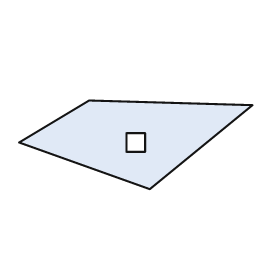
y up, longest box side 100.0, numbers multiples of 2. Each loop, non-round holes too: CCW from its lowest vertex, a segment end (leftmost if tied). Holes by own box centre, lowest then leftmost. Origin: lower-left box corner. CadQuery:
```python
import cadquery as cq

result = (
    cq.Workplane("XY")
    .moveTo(56.0, 0.0)
    .lineTo(100.0, 36.0)
    .lineTo(30.0, 38.0)
    .lineTo(0.0, 20.0)
    .close()
    .moveTo(46.0, 16.0)
    .lineTo(54.0, 16.0)
    .lineTo(54.0, 24.0)
    .lineTo(46.0, 24.0)
    .close()
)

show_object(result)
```